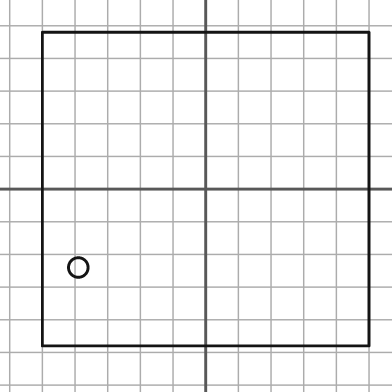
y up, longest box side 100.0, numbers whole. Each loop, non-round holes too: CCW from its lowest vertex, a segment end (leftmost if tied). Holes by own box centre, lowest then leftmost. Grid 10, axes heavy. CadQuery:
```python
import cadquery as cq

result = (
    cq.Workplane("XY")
    .moveTo(-50.0, -48.0)
    .lineTo(50.0, -48.0)
    .lineTo(50.0, 48.0)
    .lineTo(-50.0, 48.0)
    .close()
    .moveTo(-39.0, -24.0)
    .circle(3.0)
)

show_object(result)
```